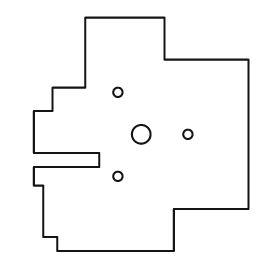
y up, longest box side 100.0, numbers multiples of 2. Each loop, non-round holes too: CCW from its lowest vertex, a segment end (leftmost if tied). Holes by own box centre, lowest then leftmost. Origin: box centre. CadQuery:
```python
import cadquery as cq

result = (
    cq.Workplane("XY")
    .moveTo(-36.0, -50.0)
    .lineTo(14.0, -50.0)
    .lineTo(14.0, -32.0)
    .lineTo(46.0, -32.0)
    .lineTo(46.0, 32.0)
    .lineTo(10.0, 32.0)
    .lineTo(10.0, 50.0)
    .lineTo(-24.0, 50.0)
    .lineTo(-24.0, 20.0)
    .lineTo(-38.0, 20.0)
    .lineTo(-38.0, 10.0)
    .lineTo(-46.0, 10.0)
    .lineTo(-46.0, -8.0)
    .lineTo(-18.0, -8.0)
    .lineTo(-18.0, -14.0)
    .lineTo(-46.0, -14.0)
    .lineTo(-46.0, -22.0)
    .lineTo(-42.0, -22.0)
    .lineTo(-42.0, -44.0)
    .lineTo(-36.0, -44.0)
    .close()
    .moveTo(-10.0, -18.0)
    .circle(2.0)
    .moveTo(0.0, 0.0)
    .circle(4.0)
    .moveTo(20.0, 0.0)
    .circle(2.0)
    .moveTo(-10.0, 18.0)
    .circle(2.0)
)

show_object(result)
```